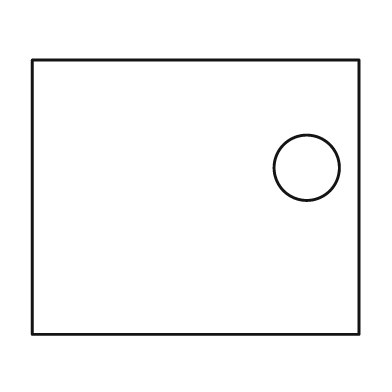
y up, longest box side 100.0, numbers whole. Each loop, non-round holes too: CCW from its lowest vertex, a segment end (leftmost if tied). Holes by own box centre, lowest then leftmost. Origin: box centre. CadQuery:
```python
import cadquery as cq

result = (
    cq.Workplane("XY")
    .moveTo(-50.0, -42.0)
    .lineTo(50.0, -42.0)
    .lineTo(50.0, 42.0)
    .lineTo(-50.0, 42.0)
    .close()
    .moveTo(34.0, 9.0)
    .circle(10.0)
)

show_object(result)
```